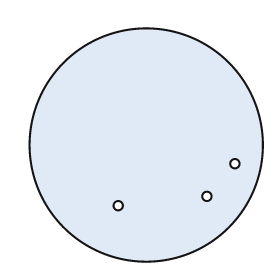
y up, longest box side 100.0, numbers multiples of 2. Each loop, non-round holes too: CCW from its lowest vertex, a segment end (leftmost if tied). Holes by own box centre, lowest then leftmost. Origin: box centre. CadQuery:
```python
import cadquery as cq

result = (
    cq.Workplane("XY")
    .moveTo(0.0, 0.0)
    .circle(50.0)
    .moveTo(-12.0, -26.0)
    .circle(2.0)
    .moveTo(26.0, -22.0)
    .circle(2.0)
    .moveTo(38.0, -8.0)
    .circle(2.0)
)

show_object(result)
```